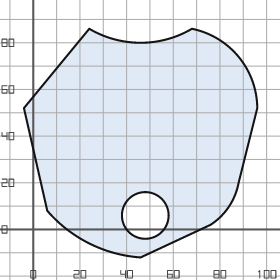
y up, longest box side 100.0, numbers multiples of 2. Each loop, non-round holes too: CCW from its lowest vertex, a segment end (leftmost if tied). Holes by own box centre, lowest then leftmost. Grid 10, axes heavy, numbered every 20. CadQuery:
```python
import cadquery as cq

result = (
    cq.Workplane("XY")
    .moveTo(46.0, -12.0)
    .lineTo(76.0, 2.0)
    .threePointArc((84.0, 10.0), (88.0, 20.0))
    .lineTo(96.0, 52.0)
    .threePointArc((88.0, 74.0), (68.0, 86.0))
    .threePointArc((46.0, 80.0), (24.0, 86.0))
    .lineTo(-4.0, 52.0)
    .lineTo(6.0, 8.0)
    .threePointArc((24.0, -6.0), (46.0, -12.0))
    .close()
    .moveTo(48.0, 6.0)
    .circle(10.0)
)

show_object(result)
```